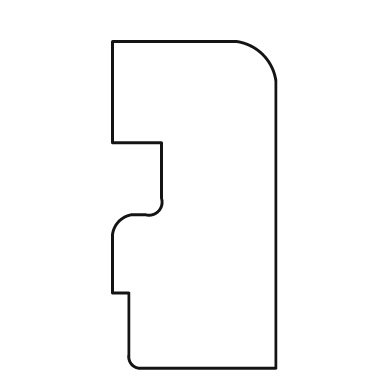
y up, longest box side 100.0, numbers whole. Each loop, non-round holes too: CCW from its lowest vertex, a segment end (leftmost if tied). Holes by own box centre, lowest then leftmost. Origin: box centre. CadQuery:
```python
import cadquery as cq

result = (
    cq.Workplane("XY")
    .moveTo(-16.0, -50.0)
    .lineTo(25.0, -50.0)
    .lineTo(25.0, 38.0)
    .threePointArc((21.0, 46.0), (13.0, 50.0))
    .lineTo(-25.0, 50.0)
    .lineTo(-25.0, 19.0)
    .lineTo(-10.0, 19.0)
    .lineTo(-10.0, 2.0)
    .threePointArc((-11.0, -2.0), (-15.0, -3.0))
    .lineTo(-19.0, -3.0)
    .threePointArc((-23.0, -5.0), (-25.0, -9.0))
    .lineTo(-25.0, -27.0)
    .lineTo(-20.0, -27.0)
    .lineTo(-20.0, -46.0)
    .threePointArc((-19.0, -49.0), (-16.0, -50.0))
    .close()
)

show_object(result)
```